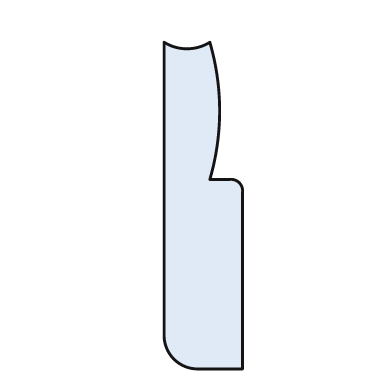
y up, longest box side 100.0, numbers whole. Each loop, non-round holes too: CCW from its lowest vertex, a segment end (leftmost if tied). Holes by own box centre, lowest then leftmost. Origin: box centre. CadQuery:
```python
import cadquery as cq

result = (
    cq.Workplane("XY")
    .moveTo(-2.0, -50.0)
    .lineTo(12.0, -50.0)
    .lineTo(12.0, 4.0)
    .threePointArc((11.0, 7.0), (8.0, 8.0))
    .lineTo(2.0, 8.0)
    .threePointArc((5.0, 29.0), (2.0, 50.0))
    .threePointArc((-5.0, 48.0), (-12.0, 50.0))
    .lineTo(-12.0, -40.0)
    .threePointArc((-9.0, -47.0), (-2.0, -50.0))
    .close()
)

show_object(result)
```